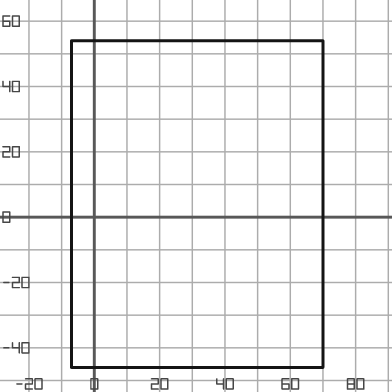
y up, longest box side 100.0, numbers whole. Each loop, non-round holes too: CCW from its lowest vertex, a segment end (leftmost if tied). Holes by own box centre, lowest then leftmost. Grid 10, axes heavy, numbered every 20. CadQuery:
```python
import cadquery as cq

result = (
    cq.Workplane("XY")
    .moveTo(-7.0, -46.0)
    .lineTo(70.0, -46.0)
    .lineTo(70.0, 54.0)
    .lineTo(-7.0, 54.0)
    .close()
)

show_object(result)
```